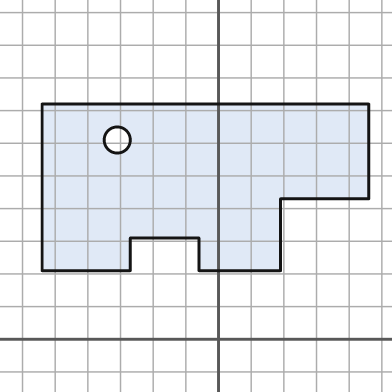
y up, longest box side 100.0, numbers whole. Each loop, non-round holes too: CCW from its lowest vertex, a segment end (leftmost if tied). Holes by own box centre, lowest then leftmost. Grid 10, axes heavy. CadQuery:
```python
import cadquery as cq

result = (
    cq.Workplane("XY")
    .moveTo(-54.0, 21.0)
    .lineTo(-27.0, 21.0)
    .lineTo(-27.0, 31.0)
    .lineTo(-6.0, 31.0)
    .lineTo(-6.0, 21.0)
    .lineTo(19.0, 21.0)
    .lineTo(19.0, 43.0)
    .lineTo(46.0, 43.0)
    .lineTo(46.0, 72.0)
    .lineTo(-54.0, 72.0)
    .close()
    .moveTo(-31.0, 61.0)
    .circle(4.0)
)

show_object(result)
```